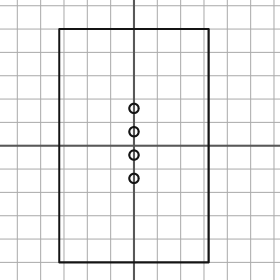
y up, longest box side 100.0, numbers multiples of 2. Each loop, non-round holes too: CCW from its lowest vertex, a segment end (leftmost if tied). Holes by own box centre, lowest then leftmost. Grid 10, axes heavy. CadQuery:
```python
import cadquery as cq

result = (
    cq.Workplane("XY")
    .moveTo(-32.0, -50.0)
    .lineTo(32.0, -50.0)
    .lineTo(32.0, 50.0)
    .lineTo(-32.0, 50.0)
    .close()
    .moveTo(0.0, -14.0)
    .circle(2.0)
    .moveTo(0.0, -4.0)
    .circle(2.0)
    .moveTo(0.0, 6.0)
    .circle(2.0)
    .moveTo(0.0, 16.0)
    .circle(2.0)
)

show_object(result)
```